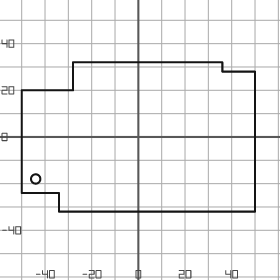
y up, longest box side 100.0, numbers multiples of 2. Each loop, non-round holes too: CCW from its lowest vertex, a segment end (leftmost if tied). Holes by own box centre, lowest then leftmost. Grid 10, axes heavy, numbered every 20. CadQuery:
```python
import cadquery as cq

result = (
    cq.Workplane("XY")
    .moveTo(-34.0, -32.0)
    .lineTo(50.0, -32.0)
    .lineTo(50.0, 28.0)
    .lineTo(36.0, 28.0)
    .lineTo(36.0, 32.0)
    .lineTo(-28.0, 32.0)
    .lineTo(-28.0, 20.0)
    .lineTo(-50.0, 20.0)
    .lineTo(-50.0, -24.0)
    .lineTo(-34.0, -24.0)
    .close()
    .moveTo(-44.0, -18.0)
    .circle(2.0)
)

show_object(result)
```